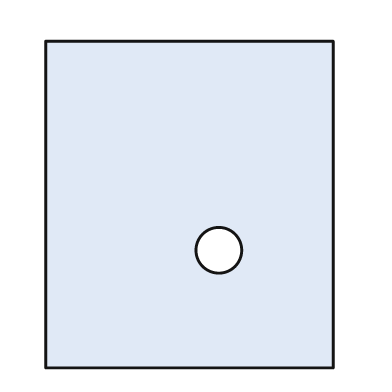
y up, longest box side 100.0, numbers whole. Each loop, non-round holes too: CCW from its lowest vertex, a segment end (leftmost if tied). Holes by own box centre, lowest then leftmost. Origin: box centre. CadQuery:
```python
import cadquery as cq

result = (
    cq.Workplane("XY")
    .moveTo(-44.0, -50.0)
    .lineTo(44.0, -50.0)
    .lineTo(44.0, 50.0)
    .lineTo(-44.0, 50.0)
    .close()
    .moveTo(9.0, -14.0)
    .circle(7.0)
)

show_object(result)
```